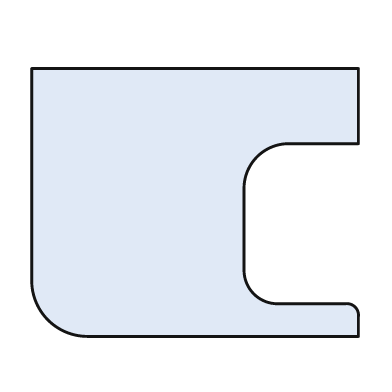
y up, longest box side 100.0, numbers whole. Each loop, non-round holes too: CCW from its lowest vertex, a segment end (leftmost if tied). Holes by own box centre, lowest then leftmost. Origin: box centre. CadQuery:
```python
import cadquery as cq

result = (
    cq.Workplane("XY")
    .moveTo(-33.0, -41.0)
    .lineTo(50.0, -41.0)
    .lineTo(50.0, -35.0)
    .threePointArc((49.0, -32.0), (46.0, -31.0))
    .lineTo(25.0, -31.0)
    .threePointArc((18.0, -28.0), (15.0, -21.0))
    .lineTo(15.0, 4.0)
    .threePointArc((19.0, 14.0), (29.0, 18.0))
    .lineTo(50.0, 18.0)
    .lineTo(50.0, 41.0)
    .lineTo(-50.0, 41.0)
    .lineTo(-50.0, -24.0)
    .threePointArc((-45.0, -36.0), (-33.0, -41.0))
    .close()
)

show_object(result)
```